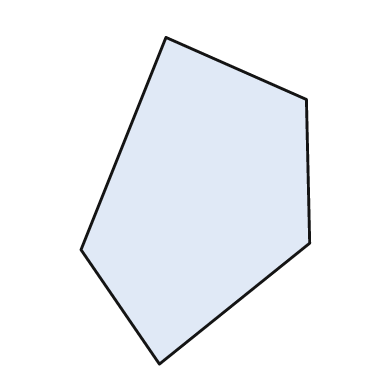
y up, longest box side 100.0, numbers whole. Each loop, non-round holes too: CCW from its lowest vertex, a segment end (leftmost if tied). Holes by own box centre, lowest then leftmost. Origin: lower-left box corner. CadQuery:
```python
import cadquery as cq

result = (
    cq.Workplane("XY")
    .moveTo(24.0, 0.0)
    .lineTo(70.0, 37.0)
    .lineTo(69.0, 81.0)
    .lineTo(26.0, 100.0)
    .lineTo(0.0, 35.0)
    .close()
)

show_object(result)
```